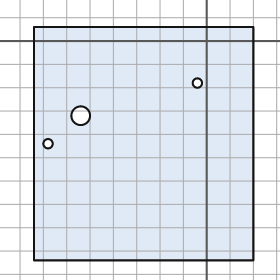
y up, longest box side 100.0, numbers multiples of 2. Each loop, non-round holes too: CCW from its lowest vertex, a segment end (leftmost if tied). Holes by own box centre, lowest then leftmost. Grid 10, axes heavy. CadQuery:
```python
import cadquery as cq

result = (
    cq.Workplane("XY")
    .moveTo(-74.0, -94.0)
    .lineTo(20.0, -94.0)
    .lineTo(20.0, 6.0)
    .lineTo(-74.0, 6.0)
    .close()
    .moveTo(-68.0, -44.0)
    .circle(2.0)
    .moveTo(-54.0, -32.0)
    .circle(4.0)
    .moveTo(-4.0, -18.0)
    .circle(2.0)
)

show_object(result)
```